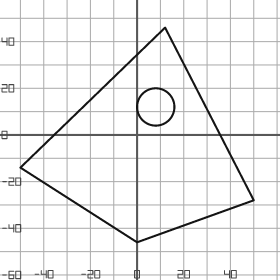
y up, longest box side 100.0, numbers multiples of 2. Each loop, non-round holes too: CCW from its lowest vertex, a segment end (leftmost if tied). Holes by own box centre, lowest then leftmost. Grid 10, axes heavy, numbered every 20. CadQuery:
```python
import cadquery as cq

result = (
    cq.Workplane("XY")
    .moveTo(0.0, -46.0)
    .lineTo(50.0, -28.0)
    .lineTo(12.0, 46.0)
    .lineTo(-50.0, -14.0)
    .close()
    .moveTo(8.0, 12.0)
    .circle(8.0)
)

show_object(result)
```